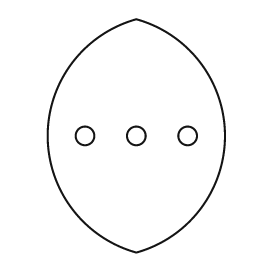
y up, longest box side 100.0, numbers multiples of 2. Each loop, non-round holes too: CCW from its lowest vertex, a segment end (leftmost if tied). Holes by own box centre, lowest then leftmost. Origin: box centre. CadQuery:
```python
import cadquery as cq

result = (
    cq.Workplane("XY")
    .moveTo(0.0, -50.0)
    .threePointArc((38.0, 0.0), (0.0, 50.0))
    .threePointArc((-38.0, 0.0), (0.0, -50.0))
    .close()
    .moveTo(-22.0, 0.0)
    .circle(4.0)
    .moveTo(0.0, 0.0)
    .circle(4.0)
    .moveTo(22.0, 0.0)
    .circle(4.0)
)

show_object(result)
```